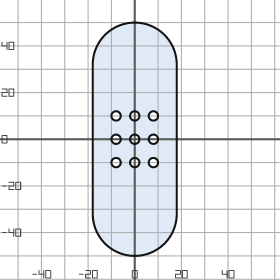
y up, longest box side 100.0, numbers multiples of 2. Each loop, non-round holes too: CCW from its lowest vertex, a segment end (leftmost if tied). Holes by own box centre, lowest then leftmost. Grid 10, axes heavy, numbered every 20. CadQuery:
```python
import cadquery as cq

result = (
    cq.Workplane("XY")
    .moveTo(-18.0, -32.0)
    .threePointArc((0.0, -50.0), (18.0, -32.0))
    .lineTo(18.0, 32.0)
    .threePointArc((0.0, 50.0), (-18.0, 32.0))
    .close()
    .moveTo(-8.0, -10.0)
    .circle(2.0)
    .moveTo(0.0, -10.0)
    .circle(2.0)
    .moveTo(8.0, -10.0)
    .circle(2.0)
    .moveTo(-8.0, 0.0)
    .circle(2.0)
    .moveTo(0.0, 0.0)
    .circle(2.0)
    .moveTo(8.0, 0.0)
    .circle(2.0)
    .moveTo(-8.0, 10.0)
    .circle(2.0)
    .moveTo(0.0, 10.0)
    .circle(2.0)
    .moveTo(8.0, 10.0)
    .circle(2.0)
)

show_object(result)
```